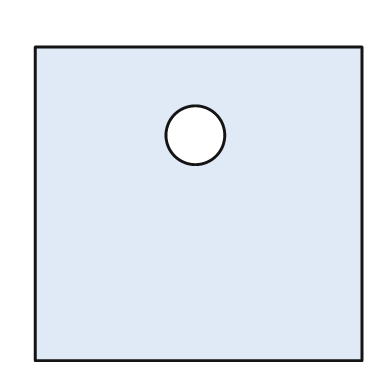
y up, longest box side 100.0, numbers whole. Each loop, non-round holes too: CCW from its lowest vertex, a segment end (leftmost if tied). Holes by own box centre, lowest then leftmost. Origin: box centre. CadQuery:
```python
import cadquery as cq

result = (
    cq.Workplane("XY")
    .moveTo(-50.0, -48.0)
    .lineTo(50.0, -48.0)
    .lineTo(50.0, 48.0)
    .lineTo(-50.0, 48.0)
    .close()
    .moveTo(-1.0, 21.0)
    .circle(9.0)
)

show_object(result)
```